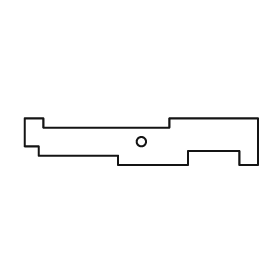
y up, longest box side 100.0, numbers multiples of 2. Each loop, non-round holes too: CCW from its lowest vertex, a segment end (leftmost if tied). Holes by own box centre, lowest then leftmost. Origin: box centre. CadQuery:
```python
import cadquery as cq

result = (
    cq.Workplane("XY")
    .moveTo(-10.0, -10.0)
    .lineTo(20.0, -10.0)
    .lineTo(20.0, -4.0)
    .lineTo(42.0, -4.0)
    .lineTo(42.0, -10.0)
    .lineTo(50.0, -10.0)
    .lineTo(50.0, 10.0)
    .lineTo(12.0, 10.0)
    .lineTo(12.0, 6.0)
    .lineTo(-42.0, 6.0)
    .lineTo(-42.0, 10.0)
    .lineTo(-50.0, 10.0)
    .lineTo(-50.0, -2.0)
    .lineTo(-44.0, -2.0)
    .lineTo(-44.0, -6.0)
    .lineTo(-10.0, -6.0)
    .close()
    .moveTo(0.0, 0.0)
    .circle(2.0)
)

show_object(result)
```